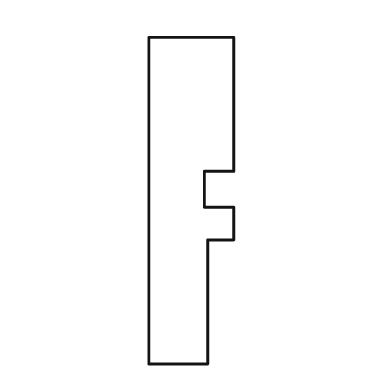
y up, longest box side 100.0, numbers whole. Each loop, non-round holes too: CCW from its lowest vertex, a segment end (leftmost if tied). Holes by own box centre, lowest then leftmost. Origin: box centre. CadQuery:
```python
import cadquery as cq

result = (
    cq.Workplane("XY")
    .moveTo(-13.0, -50.0)
    .lineTo(5.0, -50.0)
    .lineTo(5.0, -12.0)
    .lineTo(13.0, -12.0)
    .lineTo(13.0, -2.0)
    .lineTo(4.0, -2.0)
    .lineTo(4.0, 9.0)
    .lineTo(13.0, 9.0)
    .lineTo(13.0, 50.0)
    .lineTo(-13.0, 50.0)
    .close()
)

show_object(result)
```